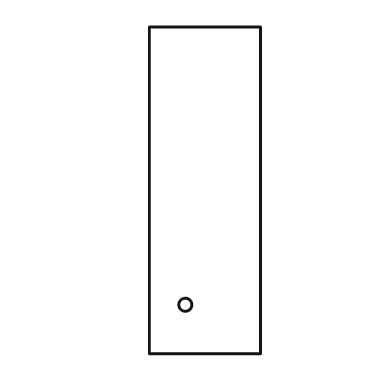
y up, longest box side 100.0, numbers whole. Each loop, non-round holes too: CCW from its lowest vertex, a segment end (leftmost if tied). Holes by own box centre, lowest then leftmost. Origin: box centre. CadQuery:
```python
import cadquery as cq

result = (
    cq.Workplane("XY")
    .moveTo(-17.0, -50.0)
    .lineTo(17.0, -50.0)
    .lineTo(17.0, 50.0)
    .lineTo(-17.0, 50.0)
    .close()
    .moveTo(-6.0, -35.0)
    .circle(2.0)
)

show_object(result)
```